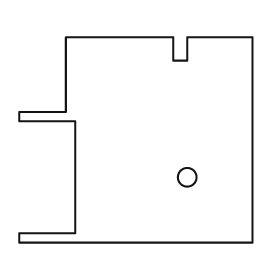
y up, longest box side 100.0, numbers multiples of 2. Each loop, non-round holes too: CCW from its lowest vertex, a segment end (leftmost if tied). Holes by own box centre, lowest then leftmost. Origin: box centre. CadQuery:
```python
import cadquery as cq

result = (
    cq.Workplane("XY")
    .moveTo(-50.0, -44.0)
    .lineTo(50.0, -44.0)
    .lineTo(50.0, 44.0)
    .lineTo(22.0, 44.0)
    .lineTo(22.0, 34.0)
    .lineTo(16.0, 34.0)
    .lineTo(16.0, 44.0)
    .lineTo(-30.0, 44.0)
    .lineTo(-30.0, 12.0)
    .lineTo(-50.0, 12.0)
    .lineTo(-50.0, 8.0)
    .lineTo(-26.0, 8.0)
    .lineTo(-26.0, -40.0)
    .lineTo(-50.0, -40.0)
    .close()
    .moveTo(22.0, -16.0)
    .circle(4.0)
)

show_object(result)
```